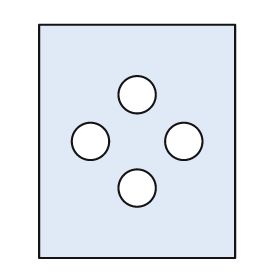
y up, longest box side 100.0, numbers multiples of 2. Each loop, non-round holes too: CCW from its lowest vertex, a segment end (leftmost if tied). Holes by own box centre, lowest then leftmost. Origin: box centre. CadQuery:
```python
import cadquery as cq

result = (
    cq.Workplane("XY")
    .moveTo(-42.0, -50.0)
    .lineTo(42.0, -50.0)
    .lineTo(42.0, 50.0)
    .lineTo(-42.0, 50.0)
    .close()
    .moveTo(0.0, -20.0)
    .circle(8.0)
    .moveTo(-20.0, 0.0)
    .circle(8.0)
    .moveTo(20.0, 0.0)
    .circle(8.0)
    .moveTo(0.0, 20.0)
    .circle(8.0)
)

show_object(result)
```